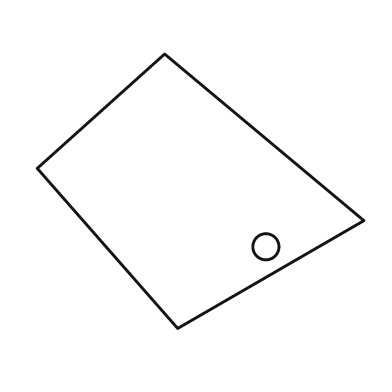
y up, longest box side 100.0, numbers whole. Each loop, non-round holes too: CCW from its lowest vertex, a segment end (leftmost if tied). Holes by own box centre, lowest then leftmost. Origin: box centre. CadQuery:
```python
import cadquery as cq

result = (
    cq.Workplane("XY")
    .moveTo(-7.0, -42.0)
    .lineTo(50.0, -9.0)
    .lineTo(-11.0, 42.0)
    .lineTo(-50.0, 7.0)
    .close()
    .moveTo(20.0, -17.0)
    .circle(4.0)
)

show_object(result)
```